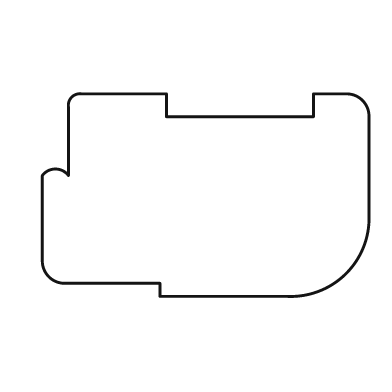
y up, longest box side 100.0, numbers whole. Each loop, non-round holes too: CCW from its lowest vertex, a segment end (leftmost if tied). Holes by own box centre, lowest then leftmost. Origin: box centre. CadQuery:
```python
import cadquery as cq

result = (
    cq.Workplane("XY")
    .moveTo(-14.0, -31.0)
    .lineTo(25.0, -31.0)
    .threePointArc((43.0, -24.0), (50.0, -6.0))
    .lineTo(50.0, 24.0)
    .threePointArc((48.0, 29.0), (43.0, 31.0))
    .lineTo(33.0, 31.0)
    .lineTo(33.0, 24.0)
    .lineTo(-12.0, 24.0)
    .lineTo(-12.0, 31.0)
    .lineTo(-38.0, 31.0)
    .threePointArc((-41.0, 30.0), (-42.0, 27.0))
    .lineTo(-42.0, 6.0)
    .threePointArc((-46.0, 8.0), (-50.0, 6.0))
    .lineTo(-50.0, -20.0)
    .threePointArc((-48.0, -25.0), (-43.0, -27.0))
    .lineTo(-14.0, -27.0)
    .close()
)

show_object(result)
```